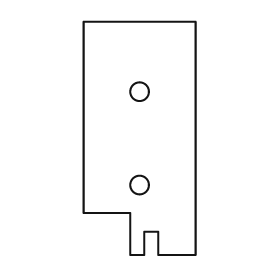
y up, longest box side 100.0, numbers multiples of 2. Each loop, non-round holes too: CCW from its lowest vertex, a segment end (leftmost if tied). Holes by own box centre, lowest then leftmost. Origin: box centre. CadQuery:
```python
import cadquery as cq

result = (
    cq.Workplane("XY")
    .moveTo(-4.0, -50.0)
    .lineTo(2.0, -50.0)
    .lineTo(2.0, -40.0)
    .lineTo(8.0, -40.0)
    .lineTo(8.0, -50.0)
    .lineTo(24.0, -50.0)
    .lineTo(24.0, 50.0)
    .lineTo(-24.0, 50.0)
    .lineTo(-24.0, -32.0)
    .lineTo(-4.0, -32.0)
    .close()
    .moveTo(0.0, -20.0)
    .circle(4.0)
    .moveTo(0.0, 20.0)
    .circle(4.0)
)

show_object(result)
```